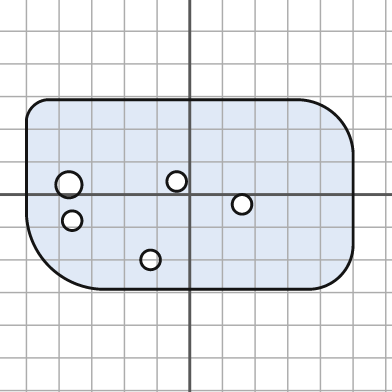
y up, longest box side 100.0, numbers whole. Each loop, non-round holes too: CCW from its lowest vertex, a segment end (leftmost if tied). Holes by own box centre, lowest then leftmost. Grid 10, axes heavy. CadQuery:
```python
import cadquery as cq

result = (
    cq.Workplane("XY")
    .moveTo(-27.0, -29.0)
    .lineTo(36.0, -29.0)
    .threePointArc((46.0, -25.0), (50.0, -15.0))
    .lineTo(50.0, 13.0)
    .threePointArc((45.0, 24.0), (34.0, 29.0))
    .lineTo(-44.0, 29.0)
    .threePointArc((-48.0, 27.0), (-50.0, 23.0))
    .lineTo(-50.0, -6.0)
    .threePointArc((-43.0, -22.0), (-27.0, -29.0))
    .close()
    .moveTo(-12.0, -20.0)
    .circle(3.0)
    .moveTo(-36.0, -8.0)
    .circle(3.0)
    .moveTo(16.0, -3.0)
    .circle(3.0)
    .moveTo(-37.0, 3.0)
    .circle(4.0)
    .moveTo(-4.0, 4.0)
    .circle(3.0)
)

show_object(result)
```